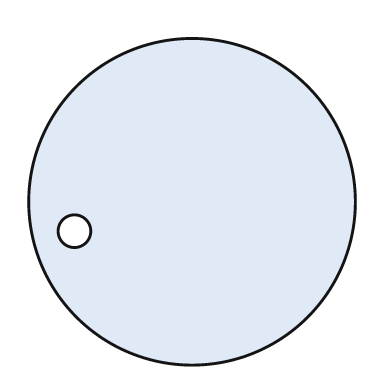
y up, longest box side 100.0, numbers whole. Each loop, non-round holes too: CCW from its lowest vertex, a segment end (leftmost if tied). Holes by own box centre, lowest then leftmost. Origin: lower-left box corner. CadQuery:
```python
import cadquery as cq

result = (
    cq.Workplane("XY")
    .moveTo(50.0, 50.0)
    .circle(50.0)
    .moveTo(14.0, 41.0)
    .circle(5.0)
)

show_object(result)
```